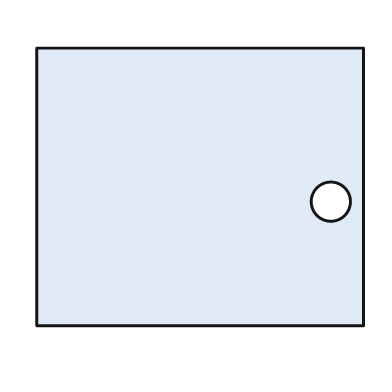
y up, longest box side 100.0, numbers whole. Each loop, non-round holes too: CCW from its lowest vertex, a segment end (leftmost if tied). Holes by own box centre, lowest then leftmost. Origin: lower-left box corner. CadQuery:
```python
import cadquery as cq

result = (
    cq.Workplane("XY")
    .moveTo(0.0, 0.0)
    .lineTo(100.0, 0.0)
    .lineTo(100.0, 85.0)
    .lineTo(0.0, 85.0)
    .close()
    .moveTo(90.0, 38.0)
    .circle(6.0)
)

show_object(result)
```